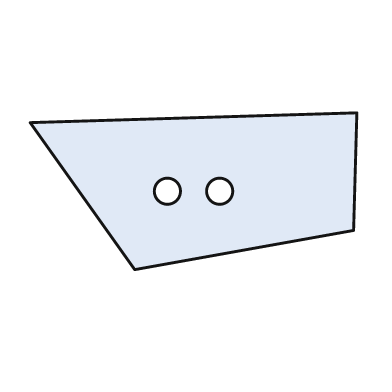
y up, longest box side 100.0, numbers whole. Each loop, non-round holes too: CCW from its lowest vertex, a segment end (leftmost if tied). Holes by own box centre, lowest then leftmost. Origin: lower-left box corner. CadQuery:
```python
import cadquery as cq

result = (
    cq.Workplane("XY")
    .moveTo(32.0, 0.0)
    .lineTo(99.0, 12.0)
    .lineTo(100.0, 48.0)
    .lineTo(0.0, 45.0)
    .close()
    .moveTo(42.0, 24.0)
    .circle(4.0)
    .moveTo(58.0, 24.0)
    .circle(4.0)
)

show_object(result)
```